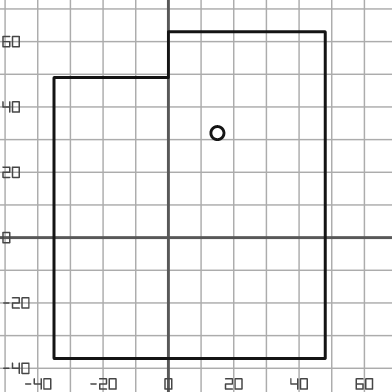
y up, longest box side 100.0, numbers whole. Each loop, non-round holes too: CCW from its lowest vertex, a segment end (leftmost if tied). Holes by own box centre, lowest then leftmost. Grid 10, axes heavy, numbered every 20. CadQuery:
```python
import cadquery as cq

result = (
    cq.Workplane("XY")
    .moveTo(-35.0, -37.0)
    .lineTo(48.0, -37.0)
    .lineTo(48.0, 63.0)
    .lineTo(0.0, 63.0)
    .lineTo(0.0, 49.0)
    .lineTo(-35.0, 49.0)
    .close()
    .moveTo(15.0, 32.0)
    .circle(2.0)
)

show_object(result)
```